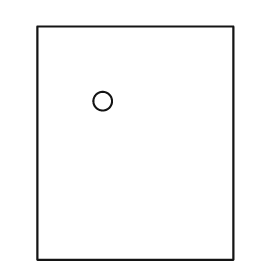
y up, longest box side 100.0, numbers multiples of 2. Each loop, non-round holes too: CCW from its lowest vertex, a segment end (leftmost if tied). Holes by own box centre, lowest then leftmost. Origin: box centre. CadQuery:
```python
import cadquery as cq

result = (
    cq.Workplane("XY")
    .moveTo(-42.0, -50.0)
    .lineTo(42.0, -50.0)
    .lineTo(42.0, 50.0)
    .lineTo(-42.0, 50.0)
    .close()
    .moveTo(-14.0, 18.0)
    .circle(4.0)
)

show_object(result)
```